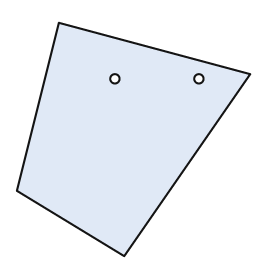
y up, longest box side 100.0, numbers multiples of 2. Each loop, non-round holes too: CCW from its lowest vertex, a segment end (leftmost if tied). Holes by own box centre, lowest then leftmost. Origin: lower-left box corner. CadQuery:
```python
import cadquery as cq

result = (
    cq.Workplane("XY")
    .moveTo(46.0, 0.0)
    .lineTo(100.0, 78.0)
    .lineTo(18.0, 100.0)
    .lineTo(0.0, 28.0)
    .close()
    .moveTo(42.0, 76.0)
    .circle(2.0)
    .moveTo(78.0, 76.0)
    .circle(2.0)
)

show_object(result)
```